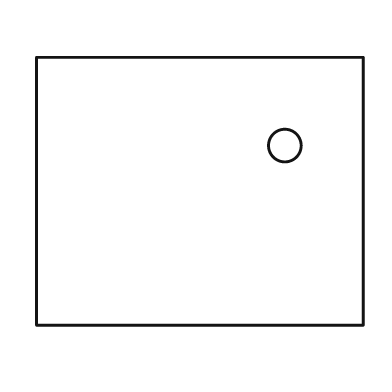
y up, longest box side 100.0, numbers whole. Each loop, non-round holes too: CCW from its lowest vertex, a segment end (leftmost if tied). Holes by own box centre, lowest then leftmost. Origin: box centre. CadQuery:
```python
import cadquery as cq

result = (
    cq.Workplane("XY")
    .moveTo(-50.0, -41.0)
    .lineTo(50.0, -41.0)
    .lineTo(50.0, 41.0)
    .lineTo(-50.0, 41.0)
    .close()
    .moveTo(26.0, 14.0)
    .circle(5.0)
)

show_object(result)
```